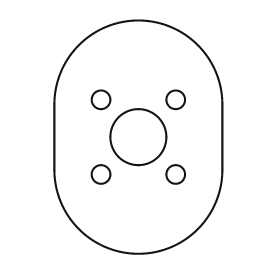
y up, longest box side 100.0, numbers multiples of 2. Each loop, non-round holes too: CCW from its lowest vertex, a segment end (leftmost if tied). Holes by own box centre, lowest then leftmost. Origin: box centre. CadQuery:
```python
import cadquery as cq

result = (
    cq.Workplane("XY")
    .moveTo(-36.0, -14.0)
    .threePointArc((0.0, -50.0), (36.0, -14.0))
    .lineTo(36.0, 14.0)
    .threePointArc((0.0, 50.0), (-36.0, 14.0))
    .close()
    .moveTo(-16.0, -16.0)
    .circle(4.0)
    .moveTo(16.0, -16.0)
    .circle(4.0)
    .moveTo(0.0, 0.0)
    .circle(12.0)
    .moveTo(-16.0, 16.0)
    .circle(4.0)
    .moveTo(16.0, 16.0)
    .circle(4.0)
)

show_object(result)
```